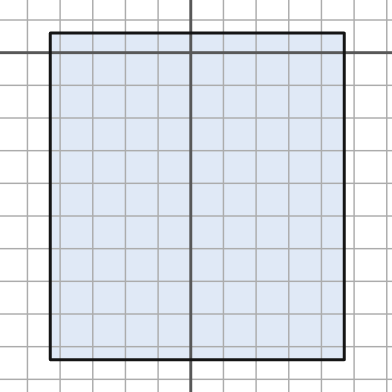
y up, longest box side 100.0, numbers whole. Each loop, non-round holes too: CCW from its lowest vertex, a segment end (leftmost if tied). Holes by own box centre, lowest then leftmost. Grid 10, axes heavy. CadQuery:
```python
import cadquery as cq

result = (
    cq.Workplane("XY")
    .moveTo(-43.0, -94.0)
    .lineTo(47.0, -94.0)
    .lineTo(47.0, 6.0)
    .lineTo(-43.0, 6.0)
    .close()
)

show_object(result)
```